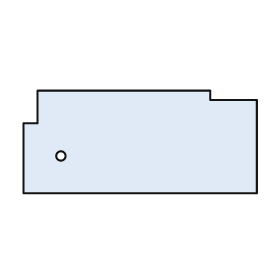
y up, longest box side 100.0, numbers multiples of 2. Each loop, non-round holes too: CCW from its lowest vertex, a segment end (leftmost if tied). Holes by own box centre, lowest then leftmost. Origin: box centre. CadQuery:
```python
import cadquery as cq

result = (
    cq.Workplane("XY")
    .moveTo(-50.0, -22.0)
    .lineTo(50.0, -22.0)
    .lineTo(50.0, 18.0)
    .lineTo(30.0, 18.0)
    .lineTo(30.0, 22.0)
    .lineTo(-44.0, 22.0)
    .lineTo(-44.0, 8.0)
    .lineTo(-50.0, 8.0)
    .close()
    .moveTo(-34.0, -6.0)
    .circle(2.0)
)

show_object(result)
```